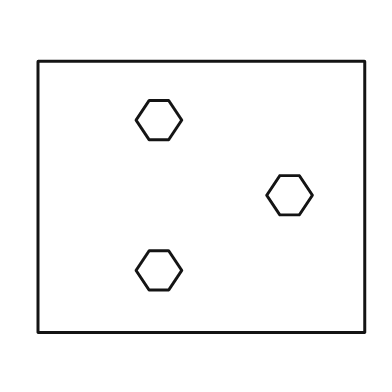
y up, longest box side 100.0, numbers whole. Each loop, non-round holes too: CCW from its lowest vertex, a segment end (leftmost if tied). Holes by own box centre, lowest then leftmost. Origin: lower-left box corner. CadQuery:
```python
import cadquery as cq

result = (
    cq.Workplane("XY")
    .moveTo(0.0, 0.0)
    .lineTo(100.0, 0.0)
    .lineTo(100.0, 83.0)
    .lineTo(0.0, 83.0)
    .close()
    .moveTo(34.0, 13.0)
    .lineTo(40.0, 13.0)
    .lineTo(44.0, 19.0)
    .lineTo(40.0, 25.0)
    .lineTo(34.0, 25.0)
    .lineTo(30.0, 19.0)
    .close()
    .moveTo(74.0, 36.0)
    .lineTo(80.0, 36.0)
    .lineTo(84.0, 42.0)
    .lineTo(80.0, 48.0)
    .lineTo(74.0, 48.0)
    .lineTo(70.0, 42.0)
    .close()
    .moveTo(34.0, 59.0)
    .lineTo(40.0, 59.0)
    .lineTo(44.0, 65.0)
    .lineTo(40.0, 71.0)
    .lineTo(34.0, 71.0)
    .lineTo(30.0, 65.0)
    .close()
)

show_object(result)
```